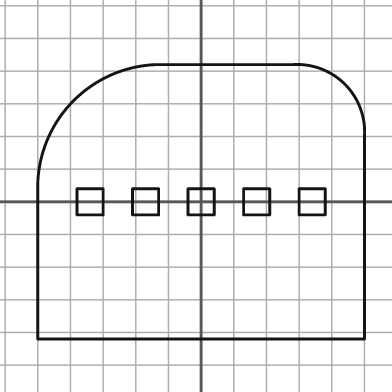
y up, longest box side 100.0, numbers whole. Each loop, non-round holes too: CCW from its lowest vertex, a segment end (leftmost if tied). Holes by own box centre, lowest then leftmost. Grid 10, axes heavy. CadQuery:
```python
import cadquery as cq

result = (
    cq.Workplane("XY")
    .moveTo(-50.0, -42.0)
    .lineTo(50.0, -42.0)
    .lineTo(50.0, 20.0)
    .threePointArc((44.0, 36.0), (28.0, 42.0))
    .lineTo(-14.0, 42.0)
    .threePointArc((-39.0, 31.0), (-50.0, 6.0))
    .close()
    .moveTo(-38.0, -4.0)
    .lineTo(-30.0, -4.0)
    .lineTo(-30.0, 4.0)
    .lineTo(-38.0, 4.0)
    .close()
    .moveTo(-21.0, -4.0)
    .lineTo(-13.0, -4.0)
    .lineTo(-13.0, 4.0)
    .lineTo(-21.0, 4.0)
    .close()
    .moveTo(-4.0, -4.0)
    .lineTo(4.0, -4.0)
    .lineTo(4.0, 4.0)
    .lineTo(-4.0, 4.0)
    .close()
    .moveTo(13.0, -4.0)
    .lineTo(21.0, -4.0)
    .lineTo(21.0, 4.0)
    .lineTo(13.0, 4.0)
    .close()
    .moveTo(30.0, -4.0)
    .lineTo(38.0, -4.0)
    .lineTo(38.0, 4.0)
    .lineTo(30.0, 4.0)
    .close()
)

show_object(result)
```